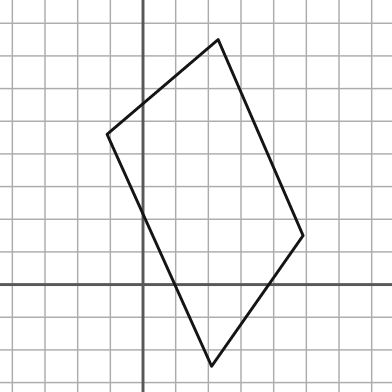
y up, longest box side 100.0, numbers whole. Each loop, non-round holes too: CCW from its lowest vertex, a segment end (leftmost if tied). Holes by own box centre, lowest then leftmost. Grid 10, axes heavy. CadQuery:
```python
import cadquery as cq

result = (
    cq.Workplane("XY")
    .moveTo(21.0, -25.0)
    .lineTo(49.0, 15.0)
    .lineTo(23.0, 75.0)
    .lineTo(-11.0, 46.0)
    .close()
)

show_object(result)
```